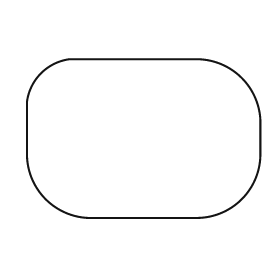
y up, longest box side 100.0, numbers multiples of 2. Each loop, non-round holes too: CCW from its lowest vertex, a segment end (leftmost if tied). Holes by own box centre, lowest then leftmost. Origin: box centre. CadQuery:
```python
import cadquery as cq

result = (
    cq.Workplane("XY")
    .moveTo(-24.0, -34.0)
    .lineTo(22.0, -34.0)
    .threePointArc((42.0, -26.0), (50.0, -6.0))
    .lineTo(50.0, 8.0)
    .threePointArc((42.0, 26.0), (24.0, 34.0))
    .lineTo(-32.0, 34.0)
    .threePointArc((-44.0, 28.0), (-50.0, 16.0))
    .lineTo(-50.0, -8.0)
    .threePointArc((-42.0, -26.0), (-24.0, -34.0))
    .close()
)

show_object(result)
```